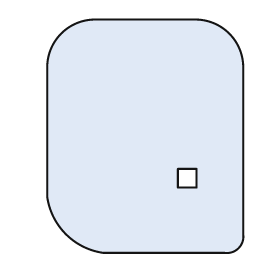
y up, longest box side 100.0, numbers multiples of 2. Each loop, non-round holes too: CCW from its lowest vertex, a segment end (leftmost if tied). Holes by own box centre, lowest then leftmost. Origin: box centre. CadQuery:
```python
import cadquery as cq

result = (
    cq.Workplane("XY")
    .moveTo(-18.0, -50.0)
    .lineTo(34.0, -50.0)
    .threePointArc((40.0, -48.0), (42.0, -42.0))
    .lineTo(42.0, 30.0)
    .threePointArc((36.0, 44.0), (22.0, 50.0))
    .lineTo(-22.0, 50.0)
    .threePointArc((-36.0, 44.0), (-42.0, 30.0))
    .lineTo(-42.0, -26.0)
    .threePointArc((-34.0, -42.0), (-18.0, -50.0))
    .close()
    .moveTo(14.0, -22.0)
    .lineTo(22.0, -22.0)
    .lineTo(22.0, -14.0)
    .lineTo(14.0, -14.0)
    .close()
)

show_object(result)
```